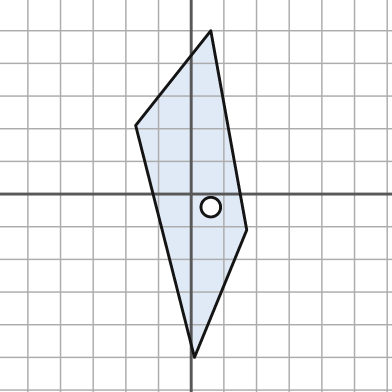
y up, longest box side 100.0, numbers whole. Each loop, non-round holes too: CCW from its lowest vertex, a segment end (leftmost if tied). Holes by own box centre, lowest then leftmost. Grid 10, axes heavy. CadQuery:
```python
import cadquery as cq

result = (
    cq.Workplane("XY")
    .moveTo(1.0, -50.0)
    .lineTo(17.0, -11.0)
    .lineTo(6.0, 50.0)
    .lineTo(-17.0, 21.0)
    .close()
    .moveTo(6.0, -4.0)
    .circle(3.0)
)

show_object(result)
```